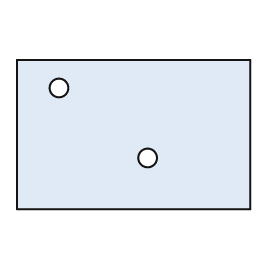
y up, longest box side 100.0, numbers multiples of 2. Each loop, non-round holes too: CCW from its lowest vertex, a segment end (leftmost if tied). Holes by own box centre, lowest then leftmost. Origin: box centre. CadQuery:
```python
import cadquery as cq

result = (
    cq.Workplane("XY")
    .moveTo(-50.0, -32.0)
    .lineTo(50.0, -32.0)
    .lineTo(50.0, 32.0)
    .lineTo(-50.0, 32.0)
    .close()
    .moveTo(6.0, -10.0)
    .circle(4.0)
    .moveTo(-32.0, 20.0)
    .circle(4.0)
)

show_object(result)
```